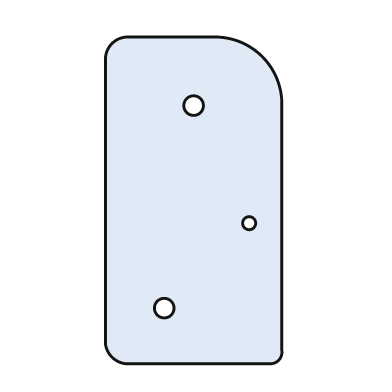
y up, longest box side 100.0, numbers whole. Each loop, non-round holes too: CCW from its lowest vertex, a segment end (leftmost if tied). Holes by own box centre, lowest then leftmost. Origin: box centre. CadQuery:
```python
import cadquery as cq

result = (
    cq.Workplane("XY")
    .moveTo(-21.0, -50.0)
    .lineTo(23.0, -50.0)
    .threePointArc((26.0, -49.0), (27.0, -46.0))
    .lineTo(27.0, 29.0)
    .threePointArc((21.0, 44.0), (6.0, 50.0))
    .lineTo(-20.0, 50.0)
    .threePointArc((-25.0, 48.0), (-27.0, 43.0))
    .lineTo(-27.0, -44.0)
    .threePointArc((-25.0, -48.0), (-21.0, -50.0))
    .close()
    .moveTo(-9.0, -33.0)
    .circle(3.0)
    .moveTo(17.0, -7.0)
    .circle(2.0)
    .moveTo(0.0, 29.0)
    .circle(3.0)
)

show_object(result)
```